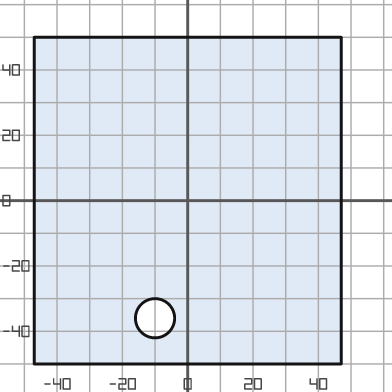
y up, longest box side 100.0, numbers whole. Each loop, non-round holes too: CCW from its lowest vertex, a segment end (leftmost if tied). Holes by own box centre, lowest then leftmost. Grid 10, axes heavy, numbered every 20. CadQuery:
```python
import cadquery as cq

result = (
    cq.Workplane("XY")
    .moveTo(-47.0, -50.0)
    .lineTo(47.0, -50.0)
    .lineTo(47.0, 50.0)
    .lineTo(-47.0, 50.0)
    .close()
    .moveTo(-10.0, -36.0)
    .circle(6.0)
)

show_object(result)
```